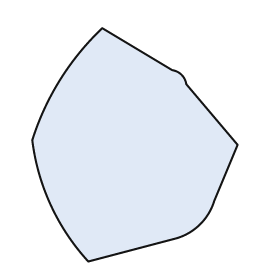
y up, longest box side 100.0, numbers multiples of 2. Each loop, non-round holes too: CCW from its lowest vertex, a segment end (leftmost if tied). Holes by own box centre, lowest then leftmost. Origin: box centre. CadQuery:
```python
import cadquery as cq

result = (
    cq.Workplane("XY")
    .moveTo(-20.0, -50.0)
    .lineTo(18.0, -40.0)
    .threePointArc((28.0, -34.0), (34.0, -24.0))
    .lineTo(44.0, 0.0)
    .lineTo(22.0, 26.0)
    .threePointArc((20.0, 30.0), (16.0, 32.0))
    .lineTo(-14.0, 50.0)
    .threePointArc((-32.0, 28.0), (-44.0, 2.0))
    .threePointArc((-36.0, -26.0), (-20.0, -50.0))
    .close()
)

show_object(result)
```